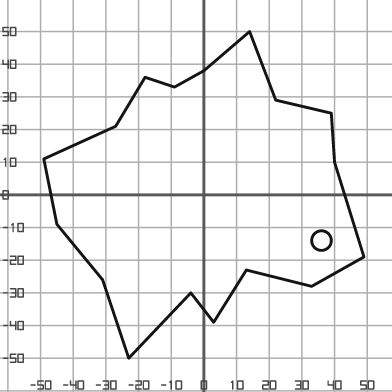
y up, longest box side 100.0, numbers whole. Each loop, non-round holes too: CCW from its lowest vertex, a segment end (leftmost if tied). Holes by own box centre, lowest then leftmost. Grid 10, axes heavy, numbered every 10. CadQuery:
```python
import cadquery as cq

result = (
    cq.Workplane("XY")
    .moveTo(-23.0, -50.0)
    .lineTo(-4.0, -30.0)
    .lineTo(3.0, -39.0)
    .lineTo(13.0, -23.0)
    .lineTo(33.0, -28.0)
    .lineTo(49.0, -19.0)
    .lineTo(40.0, 10.0)
    .lineTo(39.0, 25.0)
    .lineTo(22.0, 29.0)
    .lineTo(14.0, 50.0)
    .lineTo(0.0, 38.0)
    .lineTo(-9.0, 33.0)
    .lineTo(-18.0, 36.0)
    .lineTo(-27.0, 21.0)
    .lineTo(-49.0, 11.0)
    .lineTo(-45.0, -9.0)
    .lineTo(-31.0, -26.0)
    .close()
    .moveTo(36.0, -14.0)
    .circle(3.0)
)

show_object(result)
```